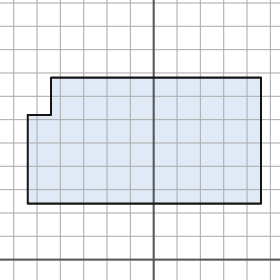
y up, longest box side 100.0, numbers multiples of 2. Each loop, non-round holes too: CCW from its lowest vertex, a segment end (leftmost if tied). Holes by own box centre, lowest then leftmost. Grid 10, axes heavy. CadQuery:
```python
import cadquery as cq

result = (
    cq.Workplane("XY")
    .moveTo(-54.0, 24.0)
    .lineTo(46.0, 24.0)
    .lineTo(46.0, 78.0)
    .lineTo(-44.0, 78.0)
    .lineTo(-44.0, 62.0)
    .lineTo(-54.0, 62.0)
    .close()
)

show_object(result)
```